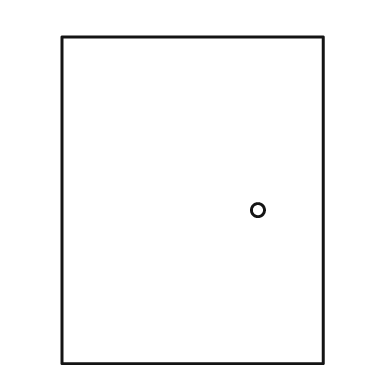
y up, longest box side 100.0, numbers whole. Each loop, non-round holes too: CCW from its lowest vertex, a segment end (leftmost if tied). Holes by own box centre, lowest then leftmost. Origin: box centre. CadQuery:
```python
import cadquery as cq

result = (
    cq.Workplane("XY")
    .moveTo(-40.0, -50.0)
    .lineTo(40.0, -50.0)
    .lineTo(40.0, 50.0)
    .lineTo(-40.0, 50.0)
    .close()
    .moveTo(20.0, -3.0)
    .circle(2.0)
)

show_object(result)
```